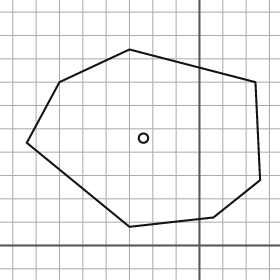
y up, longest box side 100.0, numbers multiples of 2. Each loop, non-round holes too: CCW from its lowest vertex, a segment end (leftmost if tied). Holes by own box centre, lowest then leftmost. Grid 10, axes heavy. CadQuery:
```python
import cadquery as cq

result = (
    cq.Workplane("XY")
    .moveTo(-30.0, 8.0)
    .lineTo(6.0, 12.0)
    .lineTo(26.0, 28.0)
    .lineTo(24.0, 70.0)
    .lineTo(-30.0, 84.0)
    .lineTo(-60.0, 70.0)
    .lineTo(-74.0, 44.0)
    .close()
    .moveTo(-24.0, 46.0)
    .circle(2.0)
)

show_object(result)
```